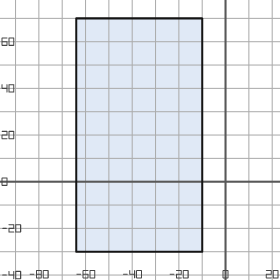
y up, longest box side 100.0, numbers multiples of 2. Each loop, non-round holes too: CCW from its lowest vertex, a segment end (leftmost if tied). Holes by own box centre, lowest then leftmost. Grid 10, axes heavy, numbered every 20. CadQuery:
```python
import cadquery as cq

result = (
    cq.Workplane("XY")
    .moveTo(-64.0, -30.0)
    .lineTo(-10.0, -30.0)
    .lineTo(-10.0, 70.0)
    .lineTo(-64.0, 70.0)
    .close()
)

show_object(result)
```